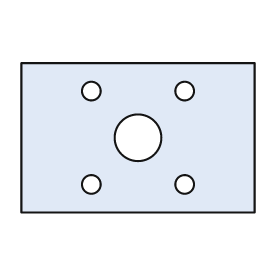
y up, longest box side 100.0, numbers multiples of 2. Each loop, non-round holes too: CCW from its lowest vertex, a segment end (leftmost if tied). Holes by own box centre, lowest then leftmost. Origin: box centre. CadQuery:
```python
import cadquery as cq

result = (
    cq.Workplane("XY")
    .moveTo(-50.0, -32.0)
    .lineTo(50.0, -32.0)
    .lineTo(50.0, 32.0)
    .lineTo(-50.0, 32.0)
    .close()
    .moveTo(-20.0, -20.0)
    .circle(4.0)
    .moveTo(20.0, -20.0)
    .circle(4.0)
    .moveTo(0.0, 0.0)
    .circle(10.0)
    .moveTo(-20.0, 20.0)
    .circle(4.0)
    .moveTo(20.0, 20.0)
    .circle(4.0)
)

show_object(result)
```